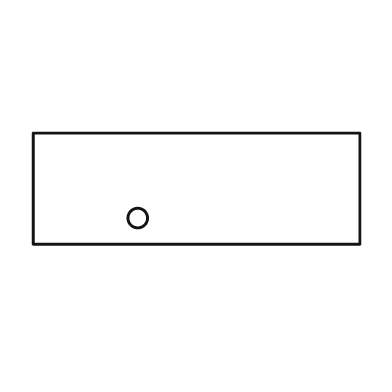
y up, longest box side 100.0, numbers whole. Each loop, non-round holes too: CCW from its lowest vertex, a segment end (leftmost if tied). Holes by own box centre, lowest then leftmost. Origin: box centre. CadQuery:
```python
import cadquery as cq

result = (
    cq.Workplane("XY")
    .moveTo(-50.0, -17.0)
    .lineTo(50.0, -17.0)
    .lineTo(50.0, 17.0)
    .lineTo(-50.0, 17.0)
    .close()
    .moveTo(-18.0, -9.0)
    .circle(3.0)
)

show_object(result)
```